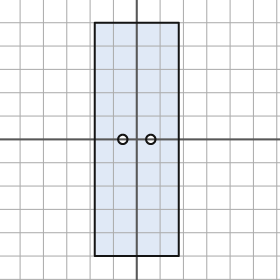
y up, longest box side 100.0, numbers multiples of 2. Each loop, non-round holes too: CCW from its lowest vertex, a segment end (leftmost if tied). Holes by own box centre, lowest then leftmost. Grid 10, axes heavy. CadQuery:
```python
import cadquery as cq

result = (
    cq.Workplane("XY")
    .moveTo(-18.0, -50.0)
    .lineTo(18.0, -50.0)
    .lineTo(18.0, 50.0)
    .lineTo(-18.0, 50.0)
    .close()
    .moveTo(-6.0, 0.0)
    .circle(2.0)
    .moveTo(6.0, 0.0)
    .circle(2.0)
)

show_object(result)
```